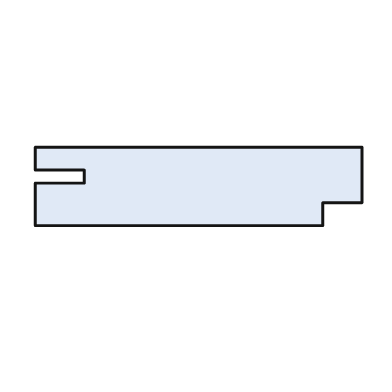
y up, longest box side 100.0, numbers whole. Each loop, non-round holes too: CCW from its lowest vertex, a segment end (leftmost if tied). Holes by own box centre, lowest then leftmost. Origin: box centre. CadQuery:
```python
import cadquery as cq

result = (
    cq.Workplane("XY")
    .moveTo(-50.0, -12.0)
    .lineTo(38.0, -12.0)
    .lineTo(38.0, -5.0)
    .lineTo(50.0, -5.0)
    .lineTo(50.0, 12.0)
    .lineTo(-50.0, 12.0)
    .lineTo(-50.0, 5.0)
    .lineTo(-35.0, 5.0)
    .lineTo(-35.0, 1.0)
    .lineTo(-50.0, 1.0)
    .close()
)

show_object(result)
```